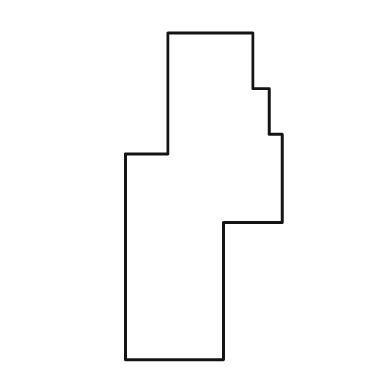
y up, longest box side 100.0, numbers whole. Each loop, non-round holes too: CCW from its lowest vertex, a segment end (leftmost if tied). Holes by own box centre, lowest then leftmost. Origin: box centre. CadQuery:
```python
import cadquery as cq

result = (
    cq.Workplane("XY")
    .moveTo(-24.0, -50.0)
    .lineTo(6.0, -50.0)
    .lineTo(6.0, -8.0)
    .lineTo(24.0, -8.0)
    .lineTo(24.0, 19.0)
    .lineTo(20.0, 19.0)
    .lineTo(20.0, 33.0)
    .lineTo(15.0, 33.0)
    .lineTo(15.0, 50.0)
    .lineTo(-11.0, 50.0)
    .lineTo(-11.0, 13.0)
    .lineTo(-24.0, 13.0)
    .close()
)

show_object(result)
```